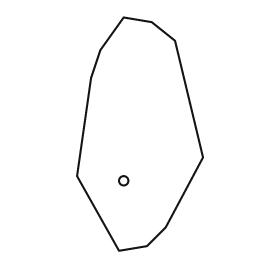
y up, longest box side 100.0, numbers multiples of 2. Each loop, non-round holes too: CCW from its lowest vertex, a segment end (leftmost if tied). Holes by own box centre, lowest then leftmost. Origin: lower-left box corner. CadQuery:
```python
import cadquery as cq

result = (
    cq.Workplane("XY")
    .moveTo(18.0, 0.0)
    .lineTo(30.0, 2.0)
    .lineTo(38.0, 10.0)
    .lineTo(54.0, 40.0)
    .lineTo(42.0, 90.0)
    .lineTo(32.0, 98.0)
    .lineTo(20.0, 100.0)
    .lineTo(10.0, 86.0)
    .lineTo(6.0, 74.0)
    .lineTo(0.0, 32.0)
    .close()
    .moveTo(20.0, 30.0)
    .circle(2.0)
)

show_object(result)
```